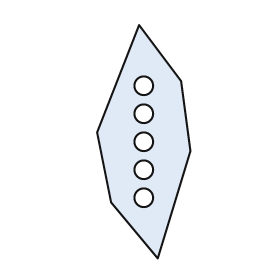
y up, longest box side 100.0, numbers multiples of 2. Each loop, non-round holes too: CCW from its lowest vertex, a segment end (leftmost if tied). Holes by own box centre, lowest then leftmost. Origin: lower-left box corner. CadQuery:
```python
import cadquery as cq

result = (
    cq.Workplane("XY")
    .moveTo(26.0, 0.0)
    .lineTo(40.0, 46.0)
    .lineTo(36.0, 76.0)
    .lineTo(18.0, 100.0)
    .lineTo(0.0, 54.0)
    .lineTo(6.0, 24.0)
    .close()
    .moveTo(20.0, 26.0)
    .circle(4.0)
    .moveTo(20.0, 38.0)
    .circle(4.0)
    .moveTo(20.0, 50.0)
    .circle(4.0)
    .moveTo(20.0, 62.0)
    .circle(4.0)
    .moveTo(20.0, 74.0)
    .circle(4.0)
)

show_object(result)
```